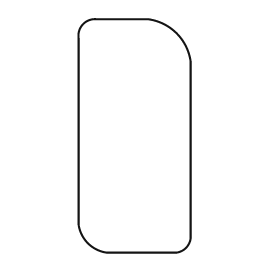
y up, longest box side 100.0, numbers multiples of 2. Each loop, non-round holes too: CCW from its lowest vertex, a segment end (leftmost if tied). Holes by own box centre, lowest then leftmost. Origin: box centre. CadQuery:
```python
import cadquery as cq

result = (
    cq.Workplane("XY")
    .moveTo(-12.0, -50.0)
    .lineTo(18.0, -50.0)
    .threePointArc((22.0, -48.0), (24.0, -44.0))
    .lineTo(24.0, 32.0)
    .threePointArc((18.0, 44.0), (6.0, 50.0))
    .lineTo(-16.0, 50.0)
    .threePointArc((-22.0, 48.0), (-24.0, 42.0))
    .lineTo(-24.0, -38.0)
    .threePointArc((-20.0, -46.0), (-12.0, -50.0))
    .close()
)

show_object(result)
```